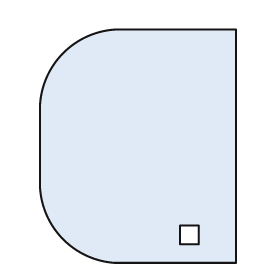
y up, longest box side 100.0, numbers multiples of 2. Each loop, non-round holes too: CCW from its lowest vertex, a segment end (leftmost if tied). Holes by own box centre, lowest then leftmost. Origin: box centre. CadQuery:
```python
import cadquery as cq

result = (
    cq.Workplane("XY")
    .moveTo(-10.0, -50.0)
    .lineTo(42.0, -50.0)
    .lineTo(42.0, 50.0)
    .lineTo(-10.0, 50.0)
    .threePointArc((-32.0, 40.0), (-42.0, 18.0))
    .lineTo(-42.0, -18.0)
    .threePointArc((-32.0, -40.0), (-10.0, -50.0))
    .close()
    .moveTo(18.0, -42.0)
    .lineTo(26.0, -42.0)
    .lineTo(26.0, -34.0)
    .lineTo(18.0, -34.0)
    .close()
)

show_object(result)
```